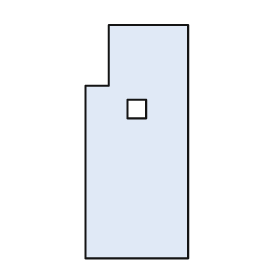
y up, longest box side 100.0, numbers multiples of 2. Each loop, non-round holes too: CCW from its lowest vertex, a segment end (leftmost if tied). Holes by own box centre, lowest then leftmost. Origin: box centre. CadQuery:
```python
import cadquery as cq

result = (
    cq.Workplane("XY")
    .moveTo(-22.0, -50.0)
    .lineTo(22.0, -50.0)
    .lineTo(22.0, 50.0)
    .lineTo(-12.0, 50.0)
    .lineTo(-12.0, 24.0)
    .lineTo(-22.0, 24.0)
    .close()
    .moveTo(-4.0, 10.0)
    .lineTo(4.0, 10.0)
    .lineTo(4.0, 18.0)
    .lineTo(-4.0, 18.0)
    .close()
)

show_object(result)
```